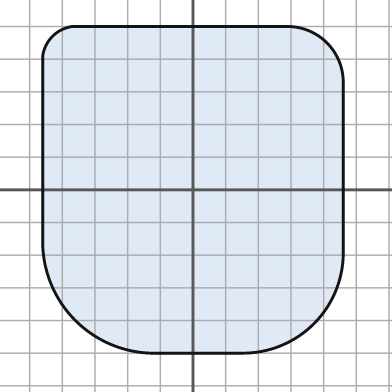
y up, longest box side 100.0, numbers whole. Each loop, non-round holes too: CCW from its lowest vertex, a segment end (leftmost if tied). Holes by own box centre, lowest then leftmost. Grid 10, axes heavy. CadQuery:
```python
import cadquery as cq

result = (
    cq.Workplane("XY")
    .moveTo(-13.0, -50.0)
    .lineTo(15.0, -50.0)
    .threePointArc((37.0, -41.0), (46.0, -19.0))
    .lineTo(46.0, 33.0)
    .threePointArc((41.0, 45.0), (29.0, 50.0))
    .lineTo(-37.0, 50.0)
    .threePointArc((-43.0, 47.0), (-46.0, 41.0))
    .lineTo(-46.0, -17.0)
    .threePointArc((-36.0, -40.0), (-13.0, -50.0))
    .close()
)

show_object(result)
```